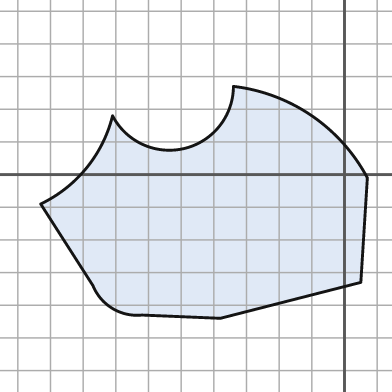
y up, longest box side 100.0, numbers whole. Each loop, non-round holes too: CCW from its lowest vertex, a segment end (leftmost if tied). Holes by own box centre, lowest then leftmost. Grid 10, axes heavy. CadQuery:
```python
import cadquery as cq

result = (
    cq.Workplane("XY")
    .moveTo(-38.0, -44.0)
    .lineTo(5.0, -33.0)
    .lineTo(7.0, -1.0)
    .threePointArc((-10.0, 18.0), (-34.0, 27.0))
    .threePointArc((-49.0, 8.0), (-71.0, 18.0))
    .threePointArc((-79.0, 2.0), (-93.0, -9.0))
    .lineTo(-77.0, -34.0)
    .threePointArc((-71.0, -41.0), (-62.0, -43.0))
    .close()
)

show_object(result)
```